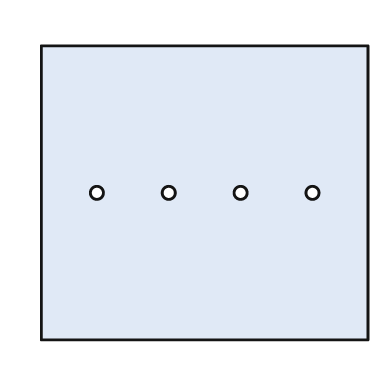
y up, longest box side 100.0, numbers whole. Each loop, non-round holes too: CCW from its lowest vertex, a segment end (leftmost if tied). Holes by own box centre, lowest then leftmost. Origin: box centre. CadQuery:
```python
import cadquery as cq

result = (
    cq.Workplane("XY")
    .moveTo(-50.0, -45.0)
    .lineTo(50.0, -45.0)
    .lineTo(50.0, 45.0)
    .lineTo(-50.0, 45.0)
    .close()
    .moveTo(-33.0, 0.0)
    .circle(2.0)
    .moveTo(-11.0, 0.0)
    .circle(2.0)
    .moveTo(11.0, 0.0)
    .circle(2.0)
    .moveTo(33.0, 0.0)
    .circle(2.0)
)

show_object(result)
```